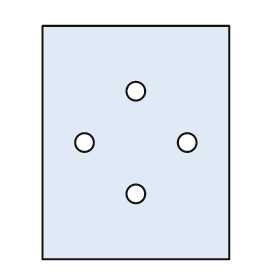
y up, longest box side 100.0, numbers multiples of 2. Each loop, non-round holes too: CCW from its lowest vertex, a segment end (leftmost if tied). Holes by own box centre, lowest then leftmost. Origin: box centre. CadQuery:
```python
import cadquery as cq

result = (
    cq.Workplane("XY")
    .moveTo(-40.0, -50.0)
    .lineTo(40.0, -50.0)
    .lineTo(40.0, 50.0)
    .lineTo(-40.0, 50.0)
    .close()
    .moveTo(0.0, -22.0)
    .circle(4.0)
    .moveTo(-22.0, 0.0)
    .circle(4.0)
    .moveTo(22.0, 0.0)
    .circle(4.0)
    .moveTo(0.0, 22.0)
    .circle(4.0)
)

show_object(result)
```